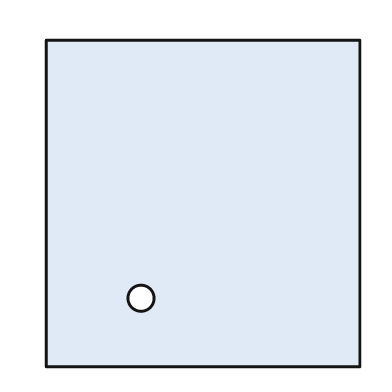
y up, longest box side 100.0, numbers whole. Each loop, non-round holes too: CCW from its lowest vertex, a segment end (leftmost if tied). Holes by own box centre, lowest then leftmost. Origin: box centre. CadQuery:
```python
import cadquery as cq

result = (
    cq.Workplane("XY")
    .moveTo(-48.0, -50.0)
    .lineTo(48.0, -50.0)
    .lineTo(48.0, 50.0)
    .lineTo(-48.0, 50.0)
    .close()
    .moveTo(-19.0, -29.0)
    .circle(4.0)
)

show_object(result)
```